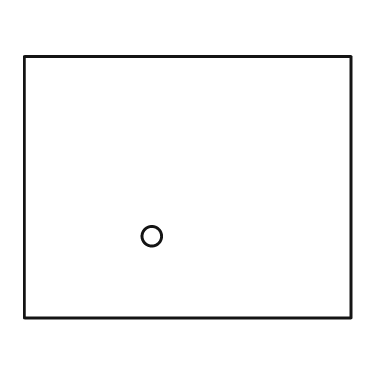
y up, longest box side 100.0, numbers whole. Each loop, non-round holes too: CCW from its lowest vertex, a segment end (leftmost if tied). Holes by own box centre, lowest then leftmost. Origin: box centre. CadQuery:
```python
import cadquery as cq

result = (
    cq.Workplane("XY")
    .moveTo(-50.0, -40.0)
    .lineTo(50.0, -40.0)
    .lineTo(50.0, 40.0)
    .lineTo(-50.0, 40.0)
    .close()
    .moveTo(-11.0, -15.0)
    .circle(3.0)
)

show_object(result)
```